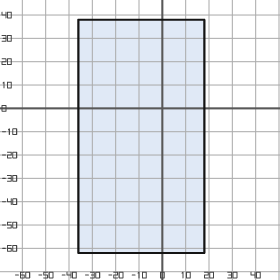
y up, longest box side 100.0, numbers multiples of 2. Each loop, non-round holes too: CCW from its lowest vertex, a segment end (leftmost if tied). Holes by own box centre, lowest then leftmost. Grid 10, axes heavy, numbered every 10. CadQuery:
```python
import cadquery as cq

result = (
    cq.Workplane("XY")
    .moveTo(-36.0, -62.0)
    .lineTo(18.0, -62.0)
    .lineTo(18.0, 38.0)
    .lineTo(-36.0, 38.0)
    .close()
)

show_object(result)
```